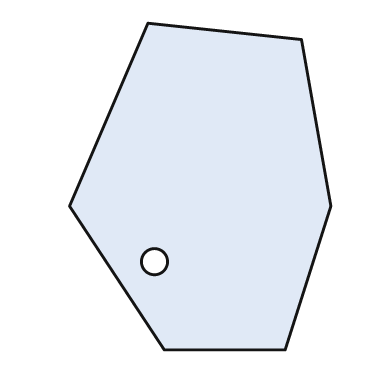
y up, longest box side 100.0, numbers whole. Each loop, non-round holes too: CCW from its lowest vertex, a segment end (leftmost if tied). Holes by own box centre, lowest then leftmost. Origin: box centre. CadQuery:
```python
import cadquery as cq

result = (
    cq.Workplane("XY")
    .moveTo(-11.0, -50.0)
    .lineTo(26.0, -50.0)
    .lineTo(40.0, -6.0)
    .lineTo(31.0, 45.0)
    .lineTo(-16.0, 50.0)
    .lineTo(-40.0, -6.0)
    .close()
    .moveTo(-14.0, -23.0)
    .circle(4.0)
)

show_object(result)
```